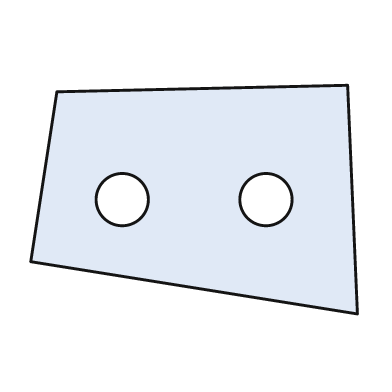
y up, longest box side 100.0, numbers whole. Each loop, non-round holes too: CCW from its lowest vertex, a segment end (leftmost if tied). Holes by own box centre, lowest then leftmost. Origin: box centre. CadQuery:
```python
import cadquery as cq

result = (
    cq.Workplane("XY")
    .moveTo(50.0, -35.0)
    .lineTo(47.0, 35.0)
    .lineTo(-42.0, 33.0)
    .lineTo(-50.0, -19.0)
    .close()
    .moveTo(-22.0, 0.0)
    .circle(8.0)
    .moveTo(22.0, 0.0)
    .circle(8.0)
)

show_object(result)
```